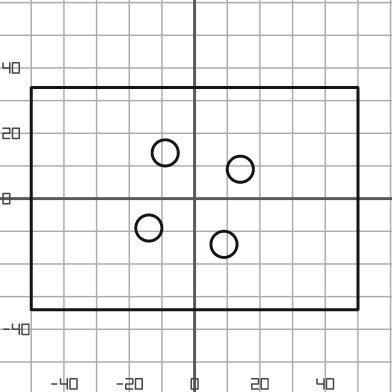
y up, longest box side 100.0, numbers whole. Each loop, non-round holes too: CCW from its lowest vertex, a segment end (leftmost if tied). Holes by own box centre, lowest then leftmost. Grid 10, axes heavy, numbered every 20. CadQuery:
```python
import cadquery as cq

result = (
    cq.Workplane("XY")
    .moveTo(-50.0, -34.0)
    .lineTo(50.0, -34.0)
    .lineTo(50.0, 34.0)
    .lineTo(-50.0, 34.0)
    .close()
    .moveTo(9.0, -14.0)
    .circle(4.0)
    .moveTo(-14.0, -9.0)
    .circle(4.0)
    .moveTo(14.0, 9.0)
    .circle(4.0)
    .moveTo(-9.0, 14.0)
    .circle(4.0)
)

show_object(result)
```